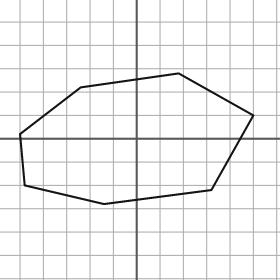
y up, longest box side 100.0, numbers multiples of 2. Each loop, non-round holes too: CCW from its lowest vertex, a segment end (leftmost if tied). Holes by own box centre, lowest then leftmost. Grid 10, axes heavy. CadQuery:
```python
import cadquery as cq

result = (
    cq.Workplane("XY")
    .moveTo(-14.0, -28.0)
    .lineTo(32.0, -22.0)
    .lineTo(50.0, 10.0)
    .lineTo(18.0, 28.0)
    .lineTo(-24.0, 22.0)
    .lineTo(-50.0, 2.0)
    .lineTo(-48.0, -20.0)
    .close()
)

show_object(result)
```